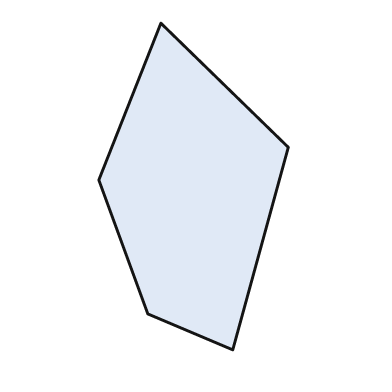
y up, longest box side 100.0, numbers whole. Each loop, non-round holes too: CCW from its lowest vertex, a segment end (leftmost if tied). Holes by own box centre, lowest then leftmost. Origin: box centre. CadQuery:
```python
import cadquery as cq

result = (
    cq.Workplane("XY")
    .moveTo(12.0, -50.0)
    .lineTo(29.0, 12.0)
    .lineTo(-10.0, 50.0)
    .lineTo(-29.0, 2.0)
    .lineTo(-14.0, -39.0)
    .close()
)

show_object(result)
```